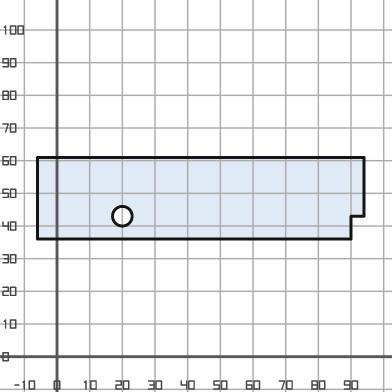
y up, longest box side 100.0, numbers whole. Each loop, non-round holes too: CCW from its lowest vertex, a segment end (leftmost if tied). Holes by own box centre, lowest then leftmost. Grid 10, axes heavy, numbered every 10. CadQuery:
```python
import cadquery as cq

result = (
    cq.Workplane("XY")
    .moveTo(-6.0, 36.0)
    .lineTo(90.0, 36.0)
    .lineTo(90.0, 43.0)
    .lineTo(94.0, 43.0)
    .lineTo(94.0, 61.0)
    .lineTo(-6.0, 61.0)
    .close()
    .moveTo(20.0, 43.0)
    .circle(3.0)
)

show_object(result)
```